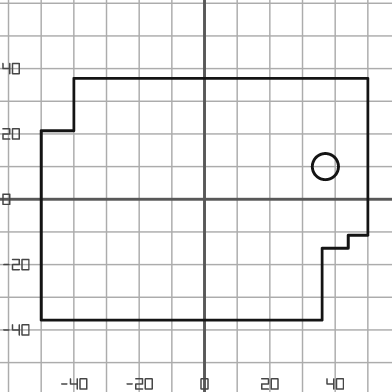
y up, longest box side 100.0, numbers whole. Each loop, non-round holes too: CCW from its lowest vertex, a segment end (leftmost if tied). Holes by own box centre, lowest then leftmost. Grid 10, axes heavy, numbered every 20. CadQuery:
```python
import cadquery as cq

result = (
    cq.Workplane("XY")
    .moveTo(-50.0, -37.0)
    .lineTo(36.0, -37.0)
    .lineTo(36.0, -15.0)
    .lineTo(44.0, -15.0)
    .lineTo(44.0, -11.0)
    .lineTo(50.0, -11.0)
    .lineTo(50.0, 37.0)
    .lineTo(-40.0, 37.0)
    .lineTo(-40.0, 21.0)
    .lineTo(-50.0, 21.0)
    .close()
    .moveTo(37.0, 10.0)
    .circle(4.0)
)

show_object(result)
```